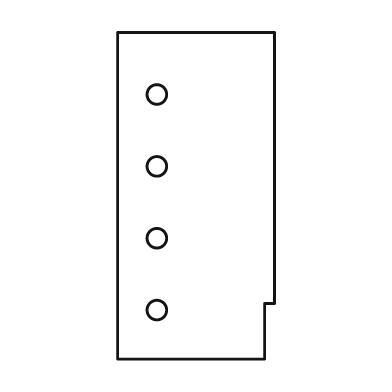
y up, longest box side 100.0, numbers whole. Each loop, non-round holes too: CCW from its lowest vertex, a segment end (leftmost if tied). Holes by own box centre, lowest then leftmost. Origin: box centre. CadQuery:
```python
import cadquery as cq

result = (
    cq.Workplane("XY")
    .moveTo(-24.0, -50.0)
    .lineTo(21.0, -50.0)
    .lineTo(21.0, -33.0)
    .lineTo(24.0, -33.0)
    .lineTo(24.0, 50.0)
    .lineTo(-24.0, 50.0)
    .close()
    .moveTo(-12.0, -35.0)
    .circle(3.0)
    .moveTo(-12.0, -13.0)
    .circle(3.0)
    .moveTo(-12.0, 9.0)
    .circle(3.0)
    .moveTo(-12.0, 31.0)
    .circle(3.0)
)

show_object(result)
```